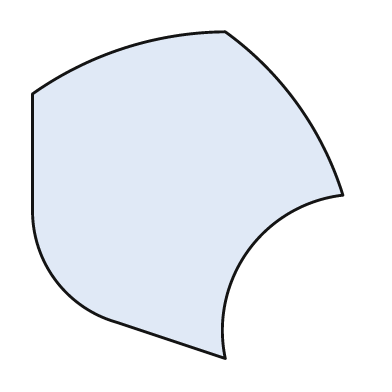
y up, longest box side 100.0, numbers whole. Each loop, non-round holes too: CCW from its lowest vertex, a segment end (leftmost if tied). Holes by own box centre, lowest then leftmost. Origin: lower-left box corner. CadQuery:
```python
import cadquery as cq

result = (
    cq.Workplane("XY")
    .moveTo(59.0, 0.0)
    .threePointArc((66.0, 33.0), (95.0, 50.0))
    .threePointArc((81.0, 78.0), (59.0, 100.0))
    .threePointArc((28.0, 95.0), (0.0, 81.0))
    .lineTo(0.0, 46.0)
    .threePointArc((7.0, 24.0), (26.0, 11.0))
    .close()
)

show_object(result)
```